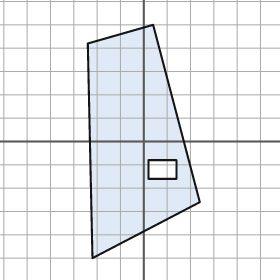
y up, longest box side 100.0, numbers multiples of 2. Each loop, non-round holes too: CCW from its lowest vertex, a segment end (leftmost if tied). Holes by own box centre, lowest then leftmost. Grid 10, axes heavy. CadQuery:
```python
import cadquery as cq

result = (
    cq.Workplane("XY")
    .moveTo(-22.0, -50.0)
    .lineTo(24.0, -26.0)
    .lineTo(4.0, 50.0)
    .lineTo(-24.0, 42.0)
    .close()
    .moveTo(2.0, -16.0)
    .lineTo(14.0, -16.0)
    .lineTo(14.0, -8.0)
    .lineTo(2.0, -8.0)
    .close()
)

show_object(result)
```